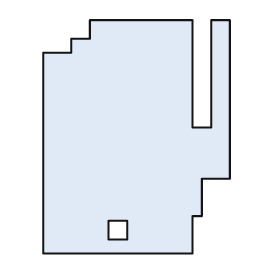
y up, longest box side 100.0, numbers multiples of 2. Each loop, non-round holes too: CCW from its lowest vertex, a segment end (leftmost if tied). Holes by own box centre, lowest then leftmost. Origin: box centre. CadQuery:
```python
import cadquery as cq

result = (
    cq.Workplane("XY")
    .moveTo(-40.0, -50.0)
    .lineTo(24.0, -50.0)
    .lineTo(24.0, -34.0)
    .lineTo(28.0, -34.0)
    .lineTo(28.0, -18.0)
    .lineTo(40.0, -18.0)
    .lineTo(40.0, 50.0)
    .lineTo(32.0, 50.0)
    .lineTo(32.0, 4.0)
    .lineTo(24.0, 4.0)
    .lineTo(24.0, 50.0)
    .lineTo(-20.0, 50.0)
    .lineTo(-20.0, 42.0)
    .lineTo(-28.0, 42.0)
    .lineTo(-28.0, 36.0)
    .lineTo(-40.0, 36.0)
    .close()
    .moveTo(-12.0, -44.0)
    .lineTo(-4.0, -44.0)
    .lineTo(-4.0, -36.0)
    .lineTo(-12.0, -36.0)
    .close()
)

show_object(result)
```